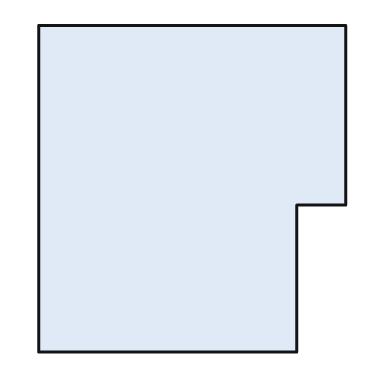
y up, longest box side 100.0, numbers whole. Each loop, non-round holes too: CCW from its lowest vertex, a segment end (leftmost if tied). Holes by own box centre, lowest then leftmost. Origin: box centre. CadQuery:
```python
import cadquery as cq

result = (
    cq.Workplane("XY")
    .moveTo(-47.0, -50.0)
    .lineTo(32.0, -50.0)
    .lineTo(32.0, -5.0)
    .lineTo(47.0, -5.0)
    .lineTo(47.0, 50.0)
    .lineTo(-47.0, 50.0)
    .close()
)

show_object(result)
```